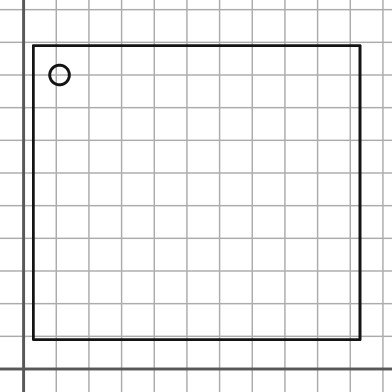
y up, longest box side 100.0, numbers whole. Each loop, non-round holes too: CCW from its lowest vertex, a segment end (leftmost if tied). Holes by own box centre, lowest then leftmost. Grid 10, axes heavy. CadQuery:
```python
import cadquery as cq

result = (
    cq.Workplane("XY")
    .moveTo(3.0, 9.0)
    .lineTo(103.0, 9.0)
    .lineTo(103.0, 99.0)
    .lineTo(3.0, 99.0)
    .close()
    .moveTo(11.0, 90.0)
    .circle(3.0)
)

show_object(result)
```